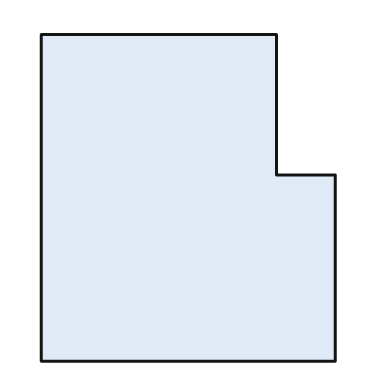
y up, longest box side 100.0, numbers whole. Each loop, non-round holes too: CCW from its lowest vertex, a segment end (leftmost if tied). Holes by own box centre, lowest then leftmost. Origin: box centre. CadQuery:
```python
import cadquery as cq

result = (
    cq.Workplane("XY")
    .moveTo(-45.0, -50.0)
    .lineTo(45.0, -50.0)
    .lineTo(45.0, 7.0)
    .lineTo(27.0, 7.0)
    .lineTo(27.0, 50.0)
    .lineTo(-45.0, 50.0)
    .close()
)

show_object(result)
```